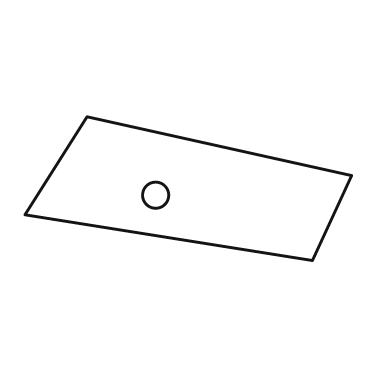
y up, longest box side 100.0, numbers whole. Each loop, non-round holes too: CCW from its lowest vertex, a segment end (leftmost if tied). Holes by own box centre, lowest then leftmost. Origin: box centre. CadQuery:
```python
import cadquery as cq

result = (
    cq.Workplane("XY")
    .moveTo(38.0, -22.0)
    .lineTo(50.0, 4.0)
    .lineTo(-31.0, 22.0)
    .lineTo(-50.0, -8.0)
    .close()
    .moveTo(-10.0, -2.0)
    .circle(4.0)
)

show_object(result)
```